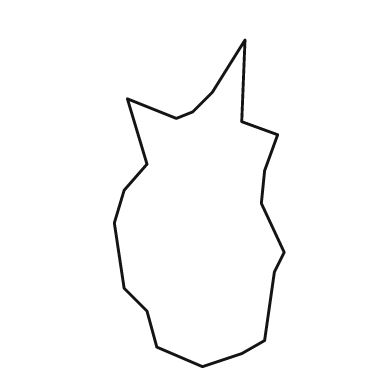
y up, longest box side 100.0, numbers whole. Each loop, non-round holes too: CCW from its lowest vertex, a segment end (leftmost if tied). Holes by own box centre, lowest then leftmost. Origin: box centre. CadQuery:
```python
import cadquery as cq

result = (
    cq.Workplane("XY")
    .moveTo(1.0, -50.0)
    .lineTo(13.0, -46.0)
    .lineTo(20.0, -42.0)
    .lineTo(23.0, -21.0)
    .lineTo(26.0, -15.0)
    .lineTo(19.0, 0.0)
    .lineTo(20.0, 10.0)
    .lineTo(24.0, 21.0)
    .lineTo(13.0, 25.0)
    .lineTo(14.0, 50.0)
    .lineTo(4.0, 34.0)
    .lineTo(-2.0, 28.0)
    .lineTo(-7.0, 26.0)
    .lineTo(-22.0, 32.0)
    .lineTo(-16.0, 12.0)
    .lineTo(-23.0, 4.0)
    .lineTo(-26.0, -6.0)
    .lineTo(-23.0, -26.0)
    .lineTo(-16.0, -33.0)
    .lineTo(-13.0, -44.0)
    .close()
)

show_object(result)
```